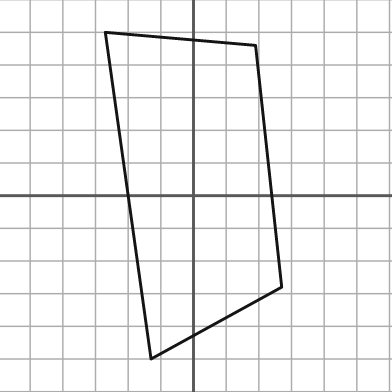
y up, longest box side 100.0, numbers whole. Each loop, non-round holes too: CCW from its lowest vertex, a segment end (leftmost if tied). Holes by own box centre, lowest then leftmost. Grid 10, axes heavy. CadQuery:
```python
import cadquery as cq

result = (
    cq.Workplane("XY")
    .moveTo(-13.0, -50.0)
    .lineTo(27.0, -28.0)
    .lineTo(19.0, 46.0)
    .lineTo(-27.0, 50.0)
    .close()
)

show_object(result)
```